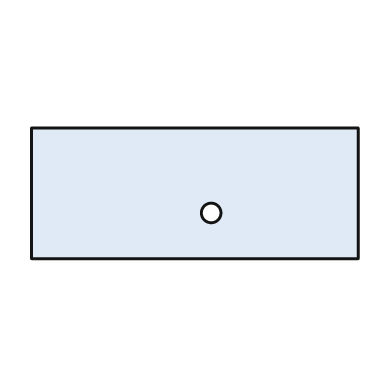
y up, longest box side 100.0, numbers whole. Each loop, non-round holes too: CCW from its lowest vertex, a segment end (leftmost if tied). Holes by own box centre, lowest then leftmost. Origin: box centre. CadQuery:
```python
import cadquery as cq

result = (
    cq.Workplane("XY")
    .moveTo(-50.0, -20.0)
    .lineTo(50.0, -20.0)
    .lineTo(50.0, 20.0)
    .lineTo(-50.0, 20.0)
    .close()
    .moveTo(5.0, -6.0)
    .circle(3.0)
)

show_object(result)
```